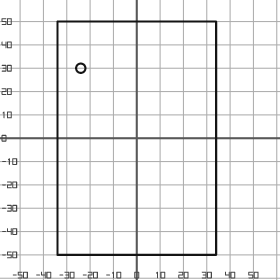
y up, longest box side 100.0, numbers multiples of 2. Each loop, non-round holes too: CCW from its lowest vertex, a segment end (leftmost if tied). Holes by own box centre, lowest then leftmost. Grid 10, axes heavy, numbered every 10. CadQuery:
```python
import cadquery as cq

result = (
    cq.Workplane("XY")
    .moveTo(-34.0, -50.0)
    .lineTo(34.0, -50.0)
    .lineTo(34.0, 50.0)
    .lineTo(-34.0, 50.0)
    .close()
    .moveTo(-24.0, 30.0)
    .circle(2.0)
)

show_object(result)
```